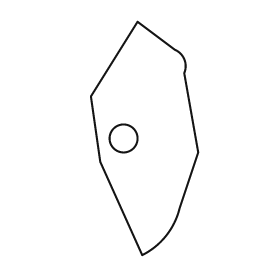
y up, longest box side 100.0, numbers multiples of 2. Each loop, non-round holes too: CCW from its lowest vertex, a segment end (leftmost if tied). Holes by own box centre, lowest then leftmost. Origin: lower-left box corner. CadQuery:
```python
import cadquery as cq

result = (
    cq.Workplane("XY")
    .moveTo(22.0, 0.0)
    .threePointArc((32.0, 8.0), (38.0, 20.0))
    .lineTo(46.0, 44.0)
    .lineTo(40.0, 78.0)
    .threePointArc((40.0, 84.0), (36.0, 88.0))
    .lineTo(20.0, 100.0)
    .lineTo(0.0, 68.0)
    .lineTo(4.0, 40.0)
    .close()
    .moveTo(14.0, 50.0)
    .circle(6.0)
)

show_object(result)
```